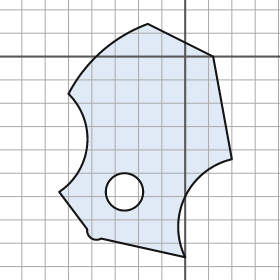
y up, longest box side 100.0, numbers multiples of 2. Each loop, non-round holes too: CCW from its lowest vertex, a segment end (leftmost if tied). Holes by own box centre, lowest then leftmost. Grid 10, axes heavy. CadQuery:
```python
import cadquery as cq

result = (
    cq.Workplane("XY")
    .moveTo(0.0, -86.0)
    .threePointArc((0.0, -60.0), (20.0, -44.0))
    .lineTo(12.0, 0.0)
    .lineTo(-16.0, 14.0)
    .threePointArc((-36.0, 2.0), (-50.0, -16.0))
    .threePointArc((-42.0, -38.0), (-54.0, -58.0))
    .lineTo(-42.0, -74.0)
    .threePointArc((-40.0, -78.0), (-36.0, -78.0))
    .close()
    .moveTo(-26.0, -58.0)
    .circle(8.0)
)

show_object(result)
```